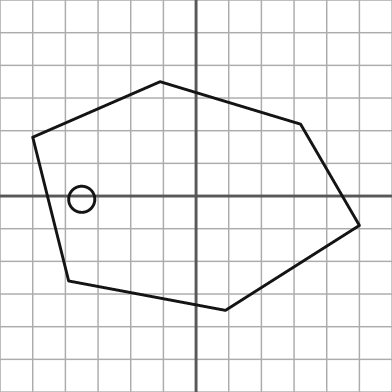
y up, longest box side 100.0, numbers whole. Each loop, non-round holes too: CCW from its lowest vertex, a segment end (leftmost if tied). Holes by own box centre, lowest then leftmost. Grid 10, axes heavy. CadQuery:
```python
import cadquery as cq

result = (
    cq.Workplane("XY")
    .moveTo(9.0, -35.0)
    .lineTo(50.0, -9.0)
    .lineTo(32.0, 22.0)
    .lineTo(-11.0, 35.0)
    .lineTo(-50.0, 18.0)
    .lineTo(-39.0, -26.0)
    .close()
    .moveTo(-35.0, -1.0)
    .circle(4.0)
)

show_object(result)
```